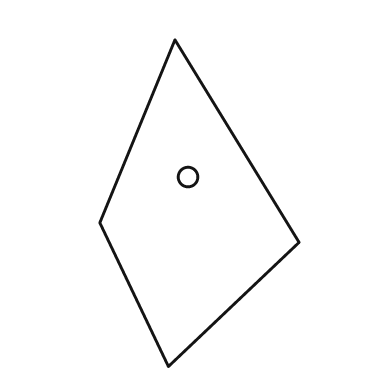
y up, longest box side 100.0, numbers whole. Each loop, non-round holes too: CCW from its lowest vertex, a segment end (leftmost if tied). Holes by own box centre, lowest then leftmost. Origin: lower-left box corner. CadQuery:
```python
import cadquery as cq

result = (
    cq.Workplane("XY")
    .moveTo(21.0, 0.0)
    .lineTo(61.0, 38.0)
    .lineTo(23.0, 100.0)
    .lineTo(0.0, 44.0)
    .close()
    .moveTo(27.0, 58.0)
    .circle(3.0)
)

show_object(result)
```